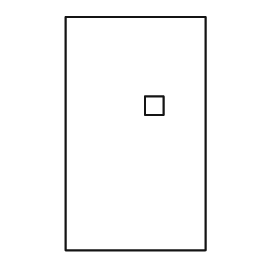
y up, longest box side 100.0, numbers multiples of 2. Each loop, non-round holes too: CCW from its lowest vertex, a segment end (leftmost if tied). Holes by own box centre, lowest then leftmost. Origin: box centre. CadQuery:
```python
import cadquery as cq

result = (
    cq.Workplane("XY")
    .moveTo(-30.0, -50.0)
    .lineTo(30.0, -50.0)
    .lineTo(30.0, 50.0)
    .lineTo(-30.0, 50.0)
    .close()
    .moveTo(4.0, 8.0)
    .lineTo(12.0, 8.0)
    .lineTo(12.0, 16.0)
    .lineTo(4.0, 16.0)
    .close()
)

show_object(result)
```